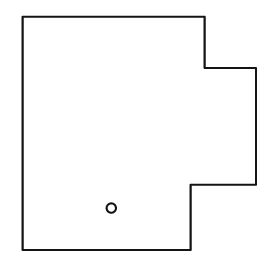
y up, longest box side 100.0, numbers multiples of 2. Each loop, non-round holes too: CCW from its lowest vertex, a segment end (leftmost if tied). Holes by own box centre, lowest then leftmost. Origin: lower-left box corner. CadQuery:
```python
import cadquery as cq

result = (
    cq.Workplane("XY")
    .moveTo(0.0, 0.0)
    .lineTo(72.0, 0.0)
    .lineTo(72.0, 28.0)
    .lineTo(100.0, 28.0)
    .lineTo(100.0, 78.0)
    .lineTo(78.0, 78.0)
    .lineTo(78.0, 100.0)
    .lineTo(0.0, 100.0)
    .close()
    .moveTo(38.0, 18.0)
    .circle(2.0)
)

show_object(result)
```